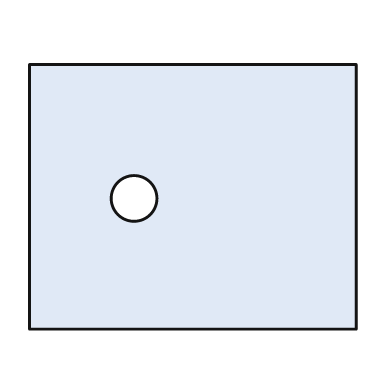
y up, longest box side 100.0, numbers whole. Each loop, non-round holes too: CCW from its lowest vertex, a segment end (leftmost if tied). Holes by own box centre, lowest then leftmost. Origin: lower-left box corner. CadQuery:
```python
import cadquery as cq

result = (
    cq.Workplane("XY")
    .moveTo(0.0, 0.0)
    .lineTo(100.0, 0.0)
    .lineTo(100.0, 81.0)
    .lineTo(0.0, 81.0)
    .close()
    .moveTo(32.0, 40.0)
    .circle(7.0)
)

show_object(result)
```